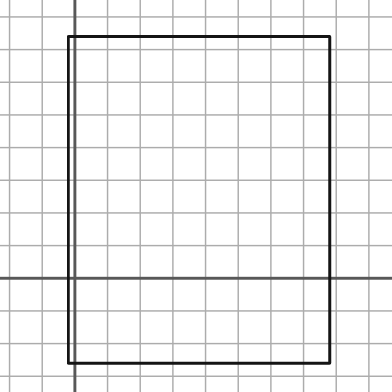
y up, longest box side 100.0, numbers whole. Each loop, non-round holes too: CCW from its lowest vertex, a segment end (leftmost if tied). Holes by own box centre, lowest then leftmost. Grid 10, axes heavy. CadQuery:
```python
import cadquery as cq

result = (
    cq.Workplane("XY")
    .moveTo(-2.0, -26.0)
    .lineTo(78.0, -26.0)
    .lineTo(78.0, 74.0)
    .lineTo(-2.0, 74.0)
    .close()
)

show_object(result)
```